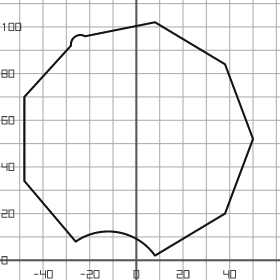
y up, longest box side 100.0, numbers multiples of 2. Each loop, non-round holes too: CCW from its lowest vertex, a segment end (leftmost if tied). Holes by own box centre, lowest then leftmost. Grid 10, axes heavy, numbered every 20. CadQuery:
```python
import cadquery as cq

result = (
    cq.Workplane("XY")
    .moveTo(8.0, 2.0)
    .lineTo(38.0, 20.0)
    .lineTo(50.0, 52.0)
    .lineTo(38.0, 84.0)
    .lineTo(8.0, 102.0)
    .lineTo(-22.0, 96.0)
    .threePointArc((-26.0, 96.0), (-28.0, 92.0))
    .lineTo(-48.0, 70.0)
    .lineTo(-48.0, 34.0)
    .lineTo(-26.0, 8.0)
    .threePointArc((-8.0, 12.0), (8.0, 2.0))
    .close()
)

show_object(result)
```